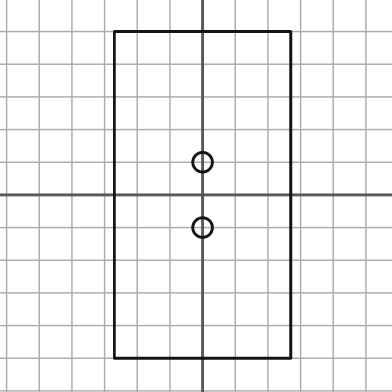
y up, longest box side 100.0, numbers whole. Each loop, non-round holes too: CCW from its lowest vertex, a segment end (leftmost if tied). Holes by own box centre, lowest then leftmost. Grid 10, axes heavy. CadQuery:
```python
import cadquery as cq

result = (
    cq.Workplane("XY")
    .moveTo(-27.0, -50.0)
    .lineTo(27.0, -50.0)
    .lineTo(27.0, 50.0)
    .lineTo(-27.0, 50.0)
    .close()
    .moveTo(0.0, -10.0)
    .circle(3.0)
    .moveTo(0.0, 10.0)
    .circle(3.0)
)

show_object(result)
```